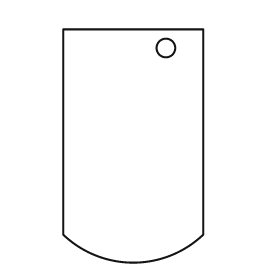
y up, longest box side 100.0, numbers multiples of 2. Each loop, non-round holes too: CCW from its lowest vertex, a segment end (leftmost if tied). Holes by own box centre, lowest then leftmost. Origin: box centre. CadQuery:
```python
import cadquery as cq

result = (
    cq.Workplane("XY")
    .moveTo(-30.0, -38.0)
    .threePointArc((0.0, -50.0), (30.0, -38.0))
    .lineTo(30.0, 50.0)
    .lineTo(-30.0, 50.0)
    .close()
    .moveTo(14.0, 42.0)
    .circle(4.0)
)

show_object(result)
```